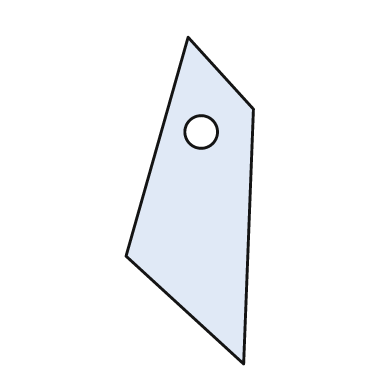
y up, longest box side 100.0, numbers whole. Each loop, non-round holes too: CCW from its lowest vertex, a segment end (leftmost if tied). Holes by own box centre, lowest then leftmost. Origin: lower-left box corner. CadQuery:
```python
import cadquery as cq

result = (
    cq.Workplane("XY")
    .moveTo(36.0, 0.0)
    .lineTo(39.0, 78.0)
    .lineTo(19.0, 100.0)
    .lineTo(0.0, 33.0)
    .close()
    .moveTo(23.0, 71.0)
    .circle(5.0)
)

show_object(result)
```